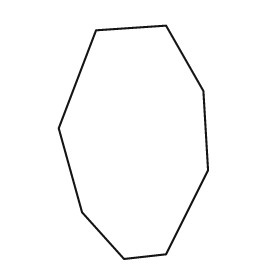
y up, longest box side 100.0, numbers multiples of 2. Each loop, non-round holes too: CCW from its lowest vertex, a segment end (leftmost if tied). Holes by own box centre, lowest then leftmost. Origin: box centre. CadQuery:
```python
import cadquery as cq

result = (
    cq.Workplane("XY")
    .moveTo(-4.0, -50.0)
    .lineTo(14.0, -48.0)
    .lineTo(32.0, -12.0)
    .lineTo(30.0, 22.0)
    .lineTo(14.0, 50.0)
    .lineTo(-16.0, 48.0)
    .lineTo(-32.0, 6.0)
    .lineTo(-22.0, -30.0)
    .close()
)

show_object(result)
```